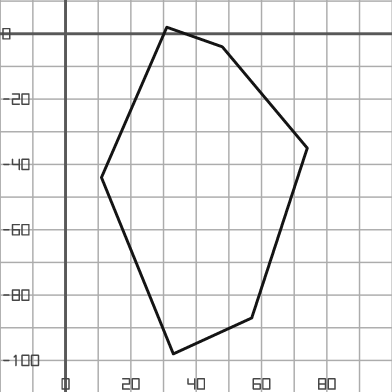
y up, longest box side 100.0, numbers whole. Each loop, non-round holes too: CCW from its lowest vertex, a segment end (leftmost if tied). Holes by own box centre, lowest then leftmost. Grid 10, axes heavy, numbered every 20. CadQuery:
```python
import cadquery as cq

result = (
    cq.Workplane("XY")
    .moveTo(33.0, -98.0)
    .lineTo(57.0, -87.0)
    .lineTo(74.0, -35.0)
    .lineTo(48.0, -4.0)
    .lineTo(31.0, 2.0)
    .lineTo(11.0, -44.0)
    .close()
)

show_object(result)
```